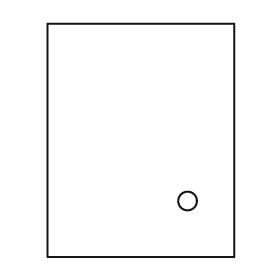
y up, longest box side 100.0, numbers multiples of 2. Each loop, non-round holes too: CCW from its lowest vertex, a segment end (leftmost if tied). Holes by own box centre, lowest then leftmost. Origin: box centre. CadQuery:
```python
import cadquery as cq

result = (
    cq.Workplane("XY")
    .moveTo(-40.0, -50.0)
    .lineTo(40.0, -50.0)
    .lineTo(40.0, 50.0)
    .lineTo(-40.0, 50.0)
    .close()
    .moveTo(20.0, -26.0)
    .circle(4.0)
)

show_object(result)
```